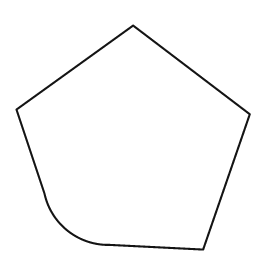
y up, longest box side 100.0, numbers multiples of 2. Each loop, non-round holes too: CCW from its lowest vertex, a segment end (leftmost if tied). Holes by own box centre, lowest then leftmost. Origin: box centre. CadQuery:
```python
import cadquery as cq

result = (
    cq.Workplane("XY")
    .moveTo(30.0, -48.0)
    .lineTo(50.0, 10.0)
    .lineTo(0.0, 48.0)
    .lineTo(-50.0, 12.0)
    .lineTo(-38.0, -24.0)
    .threePointArc((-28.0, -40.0), (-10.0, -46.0))
    .close()
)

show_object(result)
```